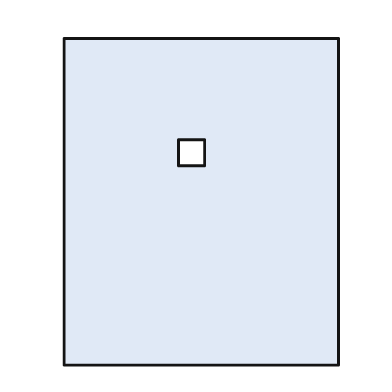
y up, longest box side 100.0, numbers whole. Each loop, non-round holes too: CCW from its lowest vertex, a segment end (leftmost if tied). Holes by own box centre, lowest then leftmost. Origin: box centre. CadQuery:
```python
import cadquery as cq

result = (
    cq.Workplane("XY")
    .moveTo(-42.0, -50.0)
    .lineTo(42.0, -50.0)
    .lineTo(42.0, 50.0)
    .lineTo(-42.0, 50.0)
    .close()
    .moveTo(-7.0, 11.0)
    .lineTo(1.0, 11.0)
    .lineTo(1.0, 19.0)
    .lineTo(-7.0, 19.0)
    .close()
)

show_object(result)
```